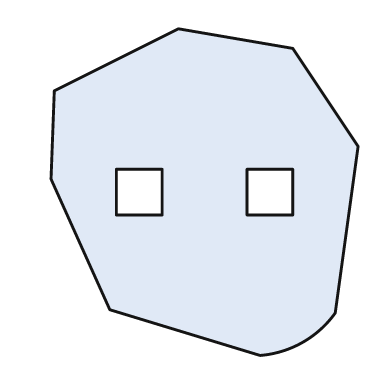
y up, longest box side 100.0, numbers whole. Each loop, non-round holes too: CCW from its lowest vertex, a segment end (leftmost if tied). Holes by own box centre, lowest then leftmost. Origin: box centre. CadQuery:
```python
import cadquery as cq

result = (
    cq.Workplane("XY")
    .moveTo(17.0, -50.0)
    .threePointArc((30.0, -46.0), (40.0, -37.0))
    .lineTo(47.0, 14.0)
    .lineTo(27.0, 44.0)
    .lineTo(-8.0, 50.0)
    .lineTo(-46.0, 31.0)
    .lineTo(-47.0, 4.0)
    .lineTo(-29.0, -36.0)
    .close()
    .moveTo(-27.0, -7.0)
    .lineTo(-13.0, -7.0)
    .lineTo(-13.0, 7.0)
    .lineTo(-27.0, 7.0)
    .close()
    .moveTo(13.0, -7.0)
    .lineTo(27.0, -7.0)
    .lineTo(27.0, 7.0)
    .lineTo(13.0, 7.0)
    .close()
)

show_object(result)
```